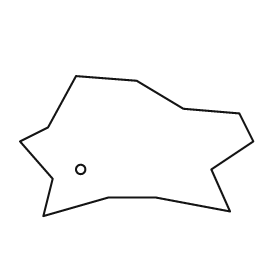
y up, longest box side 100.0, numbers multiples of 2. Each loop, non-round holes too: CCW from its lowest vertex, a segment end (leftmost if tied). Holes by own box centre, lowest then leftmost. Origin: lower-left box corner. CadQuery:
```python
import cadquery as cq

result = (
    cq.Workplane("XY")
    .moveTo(10.0, 0.0)
    .lineTo(38.0, 8.0)
    .lineTo(58.0, 8.0)
    .lineTo(90.0, 2.0)
    .lineTo(82.0, 20.0)
    .lineTo(100.0, 32.0)
    .lineTo(94.0, 44.0)
    .lineTo(70.0, 46.0)
    .lineTo(50.0, 58.0)
    .lineTo(24.0, 60.0)
    .lineTo(12.0, 38.0)
    .lineTo(0.0, 32.0)
    .lineTo(14.0, 16.0)
    .close()
    .moveTo(26.0, 20.0)
    .circle(2.0)
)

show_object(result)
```